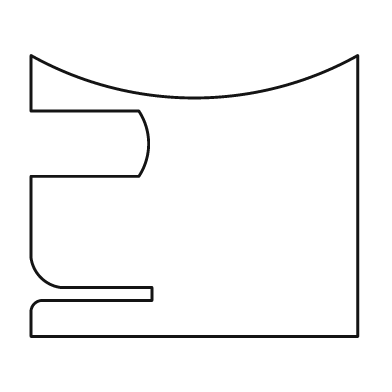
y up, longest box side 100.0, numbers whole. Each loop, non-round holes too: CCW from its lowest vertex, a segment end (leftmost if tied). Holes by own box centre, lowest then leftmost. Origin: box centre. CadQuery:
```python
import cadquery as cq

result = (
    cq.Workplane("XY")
    .moveTo(-50.0, -43.0)
    .lineTo(50.0, -43.0)
    .lineTo(50.0, 43.0)
    .threePointArc((0.0, 30.0), (-50.0, 43.0))
    .lineTo(-50.0, 26.0)
    .lineTo(-17.0, 26.0)
    .threePointArc((-14.0, 16.0), (-17.0, 6.0))
    .lineTo(-50.0, 6.0)
    .lineTo(-50.0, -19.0)
    .threePointArc((-47.0, -25.0), (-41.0, -28.0))
    .lineTo(-13.0, -28.0)
    .lineTo(-13.0, -32.0)
    .lineTo(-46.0, -32.0)
    .threePointArc((-49.0, -33.0), (-50.0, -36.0))
    .close()
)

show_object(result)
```